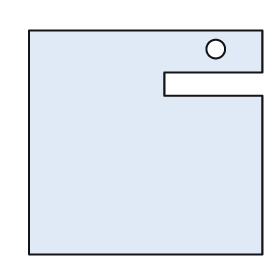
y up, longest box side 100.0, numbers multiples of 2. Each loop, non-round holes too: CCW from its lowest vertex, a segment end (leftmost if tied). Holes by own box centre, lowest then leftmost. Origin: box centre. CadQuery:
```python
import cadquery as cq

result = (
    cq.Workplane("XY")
    .moveTo(-50.0, -48.0)
    .lineTo(50.0, -48.0)
    .lineTo(50.0, 20.0)
    .lineTo(8.0, 20.0)
    .lineTo(8.0, 30.0)
    .lineTo(50.0, 30.0)
    .lineTo(50.0, 48.0)
    .lineTo(-50.0, 48.0)
    .close()
    .moveTo(30.0, 40.0)
    .circle(4.0)
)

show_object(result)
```